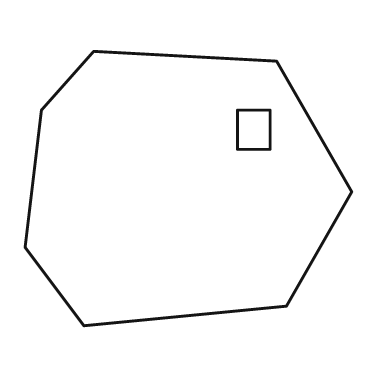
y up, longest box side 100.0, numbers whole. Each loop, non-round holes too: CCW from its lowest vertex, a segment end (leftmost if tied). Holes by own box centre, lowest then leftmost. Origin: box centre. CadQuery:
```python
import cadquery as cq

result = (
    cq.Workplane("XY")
    .moveTo(-32.0, -42.0)
    .lineTo(30.0, -36.0)
    .lineTo(50.0, -1.0)
    .lineTo(27.0, 39.0)
    .lineTo(-29.0, 42.0)
    .lineTo(-45.0, 24.0)
    .lineTo(-50.0, -18.0)
    .close()
    .moveTo(15.0, 12.0)
    .lineTo(25.0, 12.0)
    .lineTo(25.0, 24.0)
    .lineTo(15.0, 24.0)
    .close()
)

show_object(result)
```